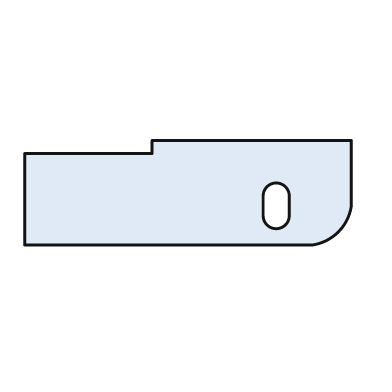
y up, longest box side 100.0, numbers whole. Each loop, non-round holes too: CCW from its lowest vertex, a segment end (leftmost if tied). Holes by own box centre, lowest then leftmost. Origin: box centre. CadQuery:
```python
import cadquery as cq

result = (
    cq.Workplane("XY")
    .moveTo(-50.0, -16.0)
    .lineTo(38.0, -16.0)
    .threePointArc((46.0, -12.0), (50.0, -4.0))
    .lineTo(50.0, 16.0)
    .lineTo(-11.0, 16.0)
    .lineTo(-11.0, 12.0)
    .lineTo(-50.0, 12.0)
    .close()
    .moveTo(23.0, -7.0)
    .threePointArc((27.0, -11.0), (31.0, -7.0))
    .lineTo(31.0, -1.0)
    .threePointArc((27.0, 3.0), (23.0, -1.0))
    .close()
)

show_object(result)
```